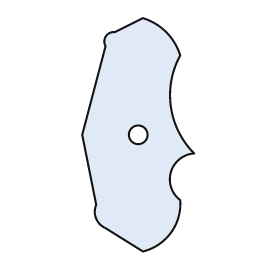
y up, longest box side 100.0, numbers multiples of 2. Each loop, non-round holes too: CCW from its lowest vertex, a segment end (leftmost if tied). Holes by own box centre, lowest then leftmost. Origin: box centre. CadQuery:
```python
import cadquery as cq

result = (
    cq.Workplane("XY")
    .moveTo(2.0, -50.0)
    .threePointArc((14.0, -42.0), (18.0, -28.0))
    .threePointArc((14.0, -16.0), (24.0, -8.0))
    .threePointArc((14.0, 12.0), (18.0, 34.0))
    .threePointArc((12.0, 44.0), (2.0, 50.0))
    .lineTo(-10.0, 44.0)
    .threePointArc((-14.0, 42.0), (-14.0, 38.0))
    .lineTo(-24.0, 0.0)
    .lineTo(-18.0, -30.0)
    .threePointArc((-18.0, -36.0), (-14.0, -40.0))
    .close()
    .moveTo(0.0, 0.0)
    .circle(4.0)
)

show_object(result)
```